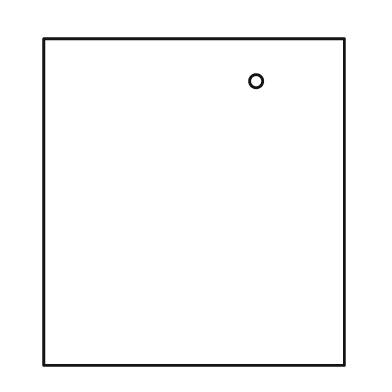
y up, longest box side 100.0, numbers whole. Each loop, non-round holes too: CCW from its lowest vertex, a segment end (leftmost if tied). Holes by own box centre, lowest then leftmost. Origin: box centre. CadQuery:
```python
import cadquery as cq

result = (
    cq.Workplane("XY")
    .moveTo(-46.0, -50.0)
    .lineTo(46.0, -50.0)
    .lineTo(46.0, 50.0)
    .lineTo(-46.0, 50.0)
    .close()
    .moveTo(19.0, 37.0)
    .circle(2.0)
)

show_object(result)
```